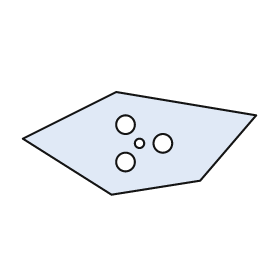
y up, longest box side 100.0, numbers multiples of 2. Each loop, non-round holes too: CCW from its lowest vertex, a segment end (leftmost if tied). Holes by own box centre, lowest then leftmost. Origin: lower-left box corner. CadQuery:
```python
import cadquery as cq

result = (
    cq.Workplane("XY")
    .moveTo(38.0, 0.0)
    .lineTo(76.0, 6.0)
    .lineTo(100.0, 34.0)
    .lineTo(40.0, 44.0)
    .lineTo(0.0, 24.0)
    .close()
    .moveTo(44.0, 14.0)
    .circle(4.0)
    .moveTo(50.0, 22.0)
    .circle(2.0)
    .moveTo(60.0, 22.0)
    .circle(4.0)
    .moveTo(44.0, 30.0)
    .circle(4.0)
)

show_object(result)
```